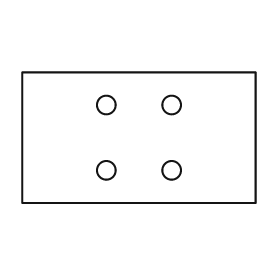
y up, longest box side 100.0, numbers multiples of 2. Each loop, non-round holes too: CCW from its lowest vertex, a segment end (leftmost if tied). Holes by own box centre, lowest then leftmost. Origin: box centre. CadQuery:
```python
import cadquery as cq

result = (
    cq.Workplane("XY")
    .moveTo(-50.0, -28.0)
    .lineTo(50.0, -28.0)
    .lineTo(50.0, 28.0)
    .lineTo(-50.0, 28.0)
    .close()
    .moveTo(-14.0, -14.0)
    .circle(4.0)
    .moveTo(14.0, -14.0)
    .circle(4.0)
    .moveTo(-14.0, 14.0)
    .circle(4.0)
    .moveTo(14.0, 14.0)
    .circle(4.0)
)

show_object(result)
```